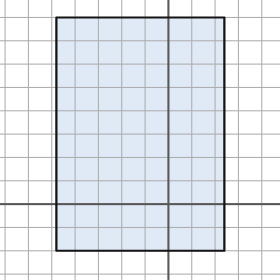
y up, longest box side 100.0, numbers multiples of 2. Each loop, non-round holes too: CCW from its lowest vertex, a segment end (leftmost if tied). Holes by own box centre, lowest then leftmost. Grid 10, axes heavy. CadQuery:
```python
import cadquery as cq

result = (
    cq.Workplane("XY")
    .moveTo(-48.0, -20.0)
    .lineTo(24.0, -20.0)
    .lineTo(24.0, 80.0)
    .lineTo(-48.0, 80.0)
    .close()
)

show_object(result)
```